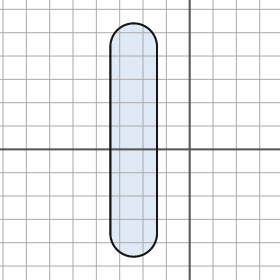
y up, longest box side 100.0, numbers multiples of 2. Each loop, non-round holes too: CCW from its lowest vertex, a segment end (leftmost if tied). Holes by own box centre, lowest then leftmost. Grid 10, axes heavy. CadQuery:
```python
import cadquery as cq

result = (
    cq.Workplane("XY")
    .moveTo(-34.0, -36.0)
    .threePointArc((-24.0, -46.0), (-14.0, -36.0))
    .lineTo(-14.0, 44.0)
    .threePointArc((-24.0, 54.0), (-34.0, 44.0))
    .close()
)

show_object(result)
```